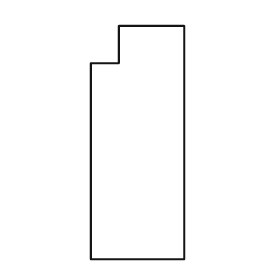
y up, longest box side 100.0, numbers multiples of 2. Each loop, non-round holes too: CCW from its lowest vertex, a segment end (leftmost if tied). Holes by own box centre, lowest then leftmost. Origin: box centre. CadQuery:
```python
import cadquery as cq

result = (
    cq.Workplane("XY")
    .moveTo(-20.0, -50.0)
    .lineTo(20.0, -50.0)
    .lineTo(20.0, 50.0)
    .lineTo(-8.0, 50.0)
    .lineTo(-8.0, 34.0)
    .lineTo(-20.0, 34.0)
    .close()
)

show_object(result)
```